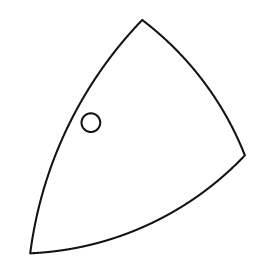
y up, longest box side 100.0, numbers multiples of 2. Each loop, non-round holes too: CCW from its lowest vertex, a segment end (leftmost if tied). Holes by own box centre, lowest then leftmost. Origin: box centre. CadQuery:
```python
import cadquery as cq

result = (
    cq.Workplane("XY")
    .moveTo(-46.0, -50.0)
    .threePointArc((4.0, -38.0), (46.0, -8.0))
    .threePointArc((28.0, 24.0), (2.0, 50.0))
    .threePointArc((-30.0, 4.0), (-46.0, -50.0))
    .close()
    .moveTo(-20.0, 6.0)
    .circle(4.0)
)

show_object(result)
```